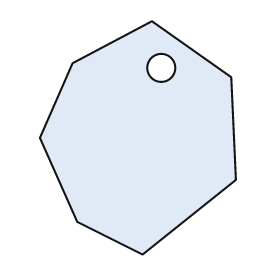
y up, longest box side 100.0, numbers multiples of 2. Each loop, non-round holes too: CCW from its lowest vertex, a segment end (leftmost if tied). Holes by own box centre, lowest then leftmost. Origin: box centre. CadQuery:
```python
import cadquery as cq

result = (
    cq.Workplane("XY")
    .moveTo(2.0, -50.0)
    .lineTo(42.0, -18.0)
    .lineTo(40.0, 26.0)
    .lineTo(6.0, 50.0)
    .lineTo(-28.0, 32.0)
    .lineTo(-42.0, 0.0)
    .lineTo(-26.0, -36.0)
    .close()
    .moveTo(10.0, 30.0)
    .circle(6.0)
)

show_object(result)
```